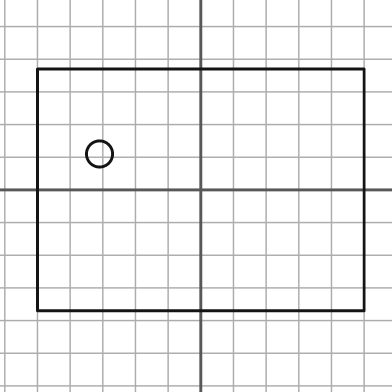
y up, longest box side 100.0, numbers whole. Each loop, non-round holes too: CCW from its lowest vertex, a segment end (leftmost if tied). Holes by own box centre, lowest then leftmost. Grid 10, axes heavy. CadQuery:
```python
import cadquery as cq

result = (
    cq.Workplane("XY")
    .moveTo(-50.0, -37.0)
    .lineTo(50.0, -37.0)
    .lineTo(50.0, 37.0)
    .lineTo(-50.0, 37.0)
    .close()
    .moveTo(-31.0, 11.0)
    .circle(4.0)
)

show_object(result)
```